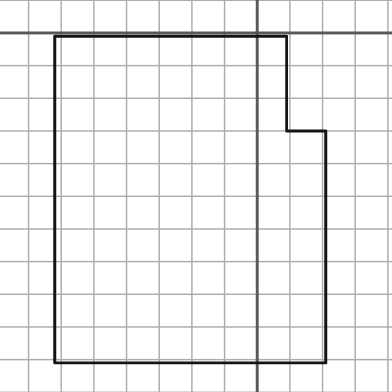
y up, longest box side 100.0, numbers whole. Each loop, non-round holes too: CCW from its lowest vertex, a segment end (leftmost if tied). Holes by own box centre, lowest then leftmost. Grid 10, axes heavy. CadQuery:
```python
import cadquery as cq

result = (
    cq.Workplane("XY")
    .moveTo(-62.0, -101.0)
    .lineTo(21.0, -101.0)
    .lineTo(21.0, -30.0)
    .lineTo(9.0, -30.0)
    .lineTo(9.0, -1.0)
    .lineTo(-62.0, -1.0)
    .close()
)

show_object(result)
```